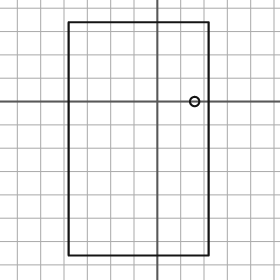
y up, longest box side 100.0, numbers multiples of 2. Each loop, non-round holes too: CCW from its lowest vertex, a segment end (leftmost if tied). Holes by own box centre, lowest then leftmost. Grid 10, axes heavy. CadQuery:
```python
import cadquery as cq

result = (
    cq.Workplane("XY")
    .moveTo(-38.0, -66.0)
    .lineTo(22.0, -66.0)
    .lineTo(22.0, 34.0)
    .lineTo(-38.0, 34.0)
    .close()
    .moveTo(16.0, 0.0)
    .circle(2.0)
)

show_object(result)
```